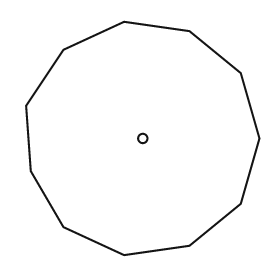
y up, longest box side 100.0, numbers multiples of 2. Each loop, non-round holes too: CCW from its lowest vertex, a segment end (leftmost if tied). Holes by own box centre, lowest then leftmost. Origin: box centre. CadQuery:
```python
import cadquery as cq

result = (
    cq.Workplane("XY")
    .moveTo(-8.0, -50.0)
    .lineTo(20.0, -46.0)
    .lineTo(42.0, -28.0)
    .lineTo(50.0, 0.0)
    .lineTo(42.0, 28.0)
    .lineTo(20.0, 46.0)
    .lineTo(-8.0, 50.0)
    .lineTo(-34.0, 38.0)
    .lineTo(-50.0, 14.0)
    .lineTo(-48.0, -14.0)
    .lineTo(-34.0, -38.0)
    .close()
    .moveTo(0.0, 0.0)
    .circle(2.0)
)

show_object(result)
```